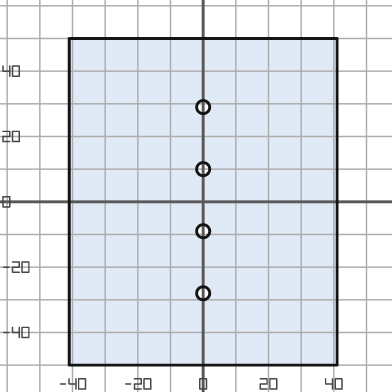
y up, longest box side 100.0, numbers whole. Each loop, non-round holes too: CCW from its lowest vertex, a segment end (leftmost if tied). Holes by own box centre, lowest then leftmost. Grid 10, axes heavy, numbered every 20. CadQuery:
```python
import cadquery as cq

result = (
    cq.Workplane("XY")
    .moveTo(-41.0, -50.0)
    .lineTo(41.0, -50.0)
    .lineTo(41.0, 50.0)
    .lineTo(-41.0, 50.0)
    .close()
    .moveTo(0.0, -28.0)
    .circle(2.0)
    .moveTo(0.0, -9.0)
    .circle(2.0)
    .moveTo(0.0, 10.0)
    .circle(2.0)
    .moveTo(0.0, 29.0)
    .circle(2.0)
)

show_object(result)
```